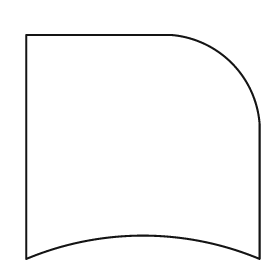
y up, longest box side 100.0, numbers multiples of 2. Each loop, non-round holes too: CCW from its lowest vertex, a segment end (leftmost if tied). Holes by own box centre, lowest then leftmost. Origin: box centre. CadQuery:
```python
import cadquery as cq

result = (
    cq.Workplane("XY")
    .moveTo(-50.0, -48.0)
    .threePointArc((0.0, -38.0), (50.0, -48.0))
    .lineTo(50.0, 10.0)
    .threePointArc((38.0, 36.0), (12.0, 48.0))
    .lineTo(-50.0, 48.0)
    .close()
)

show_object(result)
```